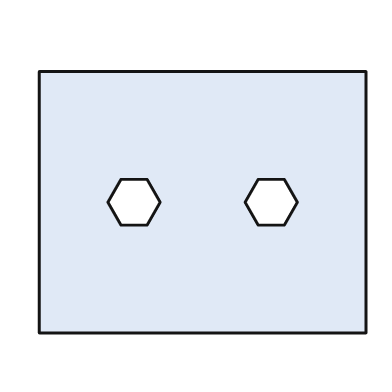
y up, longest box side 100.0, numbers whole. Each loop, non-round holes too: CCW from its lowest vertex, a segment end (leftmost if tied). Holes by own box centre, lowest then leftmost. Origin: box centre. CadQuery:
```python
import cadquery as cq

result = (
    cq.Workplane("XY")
    .moveTo(-50.0, -40.0)
    .lineTo(50.0, -40.0)
    .lineTo(50.0, 40.0)
    .lineTo(-50.0, 40.0)
    .close()
    .moveTo(-25.0, -7.0)
    .lineTo(-17.0, -7.0)
    .lineTo(-13.0, 0.0)
    .lineTo(-17.0, 7.0)
    .lineTo(-25.0, 7.0)
    .lineTo(-29.0, 0.0)
    .close()
    .moveTo(17.0, -7.0)
    .lineTo(25.0, -7.0)
    .lineTo(29.0, 0.0)
    .lineTo(25.0, 7.0)
    .lineTo(17.0, 7.0)
    .lineTo(13.0, 0.0)
    .close()
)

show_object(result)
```